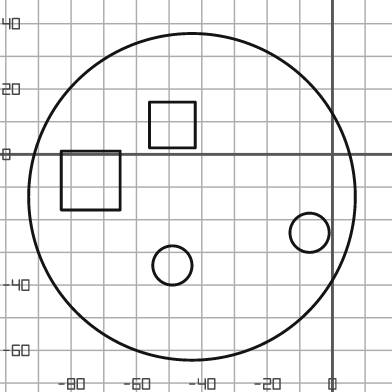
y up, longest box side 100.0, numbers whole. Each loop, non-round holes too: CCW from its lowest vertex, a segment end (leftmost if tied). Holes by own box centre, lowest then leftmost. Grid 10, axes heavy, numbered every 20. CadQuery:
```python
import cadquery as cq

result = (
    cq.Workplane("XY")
    .moveTo(-43.0, -13.0)
    .circle(50.0)
    .moveTo(-49.0, -34.0)
    .circle(6.0)
    .moveTo(-7.0, -24.0)
    .circle(6.0)
    .moveTo(-83.0, -17.0)
    .lineTo(-65.0, -17.0)
    .lineTo(-65.0, 1.0)
    .lineTo(-83.0, 1.0)
    .close()
    .moveTo(-56.0, 2.0)
    .lineTo(-42.0, 2.0)
    .lineTo(-42.0, 16.0)
    .lineTo(-56.0, 16.0)
    .close()
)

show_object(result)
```